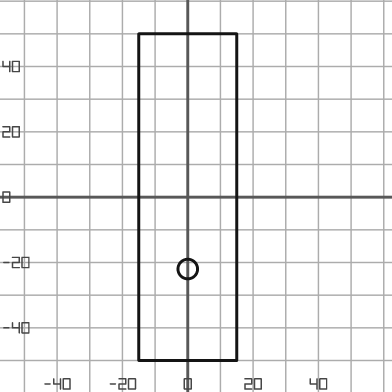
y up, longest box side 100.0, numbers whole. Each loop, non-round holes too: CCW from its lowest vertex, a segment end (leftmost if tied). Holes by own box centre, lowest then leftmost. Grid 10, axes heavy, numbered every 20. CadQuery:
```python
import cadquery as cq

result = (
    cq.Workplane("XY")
    .moveTo(-15.0, -50.0)
    .lineTo(15.0, -50.0)
    .lineTo(15.0, 50.0)
    .lineTo(-15.0, 50.0)
    .close()
    .moveTo(0.0, -22.0)
    .circle(3.0)
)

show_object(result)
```